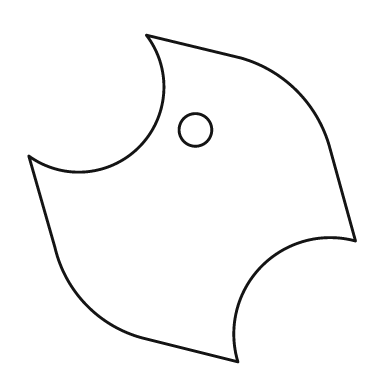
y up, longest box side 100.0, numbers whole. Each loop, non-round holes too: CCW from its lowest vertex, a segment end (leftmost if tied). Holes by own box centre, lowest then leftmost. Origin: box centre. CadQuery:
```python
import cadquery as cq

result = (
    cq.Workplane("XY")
    .moveTo(14.0, -50.0)
    .threePointArc((21.0, -21.0), (50.0, -13.0))
    .lineTo(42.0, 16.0)
    .threePointArc((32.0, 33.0), (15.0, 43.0))
    .lineTo(-14.0, 50.0)
    .threePointArc((-16.0, 16.0), (-50.0, 13.0))
    .lineTo(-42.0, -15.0)
    .threePointArc((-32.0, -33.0), (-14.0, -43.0))
    .close()
    .moveTo(1.0, 21.0)
    .circle(5.0)
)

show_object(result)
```